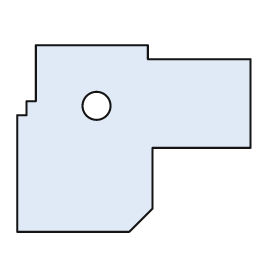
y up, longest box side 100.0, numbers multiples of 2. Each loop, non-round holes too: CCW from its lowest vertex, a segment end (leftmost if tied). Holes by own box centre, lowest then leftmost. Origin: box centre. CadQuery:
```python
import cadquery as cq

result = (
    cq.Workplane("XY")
    .moveTo(-50.0, -40.0)
    .lineTo(-2.0, -40.0)
    .lineTo(8.0, -30.0)
    .lineTo(8.0, -4.0)
    .lineTo(50.0, -4.0)
    .lineTo(50.0, 34.0)
    .lineTo(6.0, 34.0)
    .lineTo(6.0, 40.0)
    .lineTo(-42.0, 40.0)
    .lineTo(-42.0, 16.0)
    .lineTo(-46.0, 16.0)
    .lineTo(-46.0, 10.0)
    .lineTo(-50.0, 10.0)
    .close()
    .moveTo(-16.0, 14.0)
    .circle(6.0)
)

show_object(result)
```